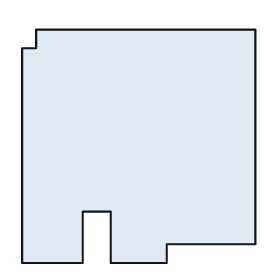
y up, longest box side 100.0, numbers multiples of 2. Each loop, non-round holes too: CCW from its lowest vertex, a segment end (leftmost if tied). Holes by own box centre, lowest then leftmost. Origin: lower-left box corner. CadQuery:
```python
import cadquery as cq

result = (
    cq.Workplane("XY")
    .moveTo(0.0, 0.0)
    .lineTo(26.0, 0.0)
    .lineTo(26.0, 22.0)
    .lineTo(38.0, 22.0)
    .lineTo(38.0, 0.0)
    .lineTo(62.0, 0.0)
    .lineTo(62.0, 8.0)
    .lineTo(100.0, 8.0)
    .lineTo(100.0, 100.0)
    .lineTo(6.0, 100.0)
    .lineTo(6.0, 92.0)
    .lineTo(0.0, 92.0)
    .close()
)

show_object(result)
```